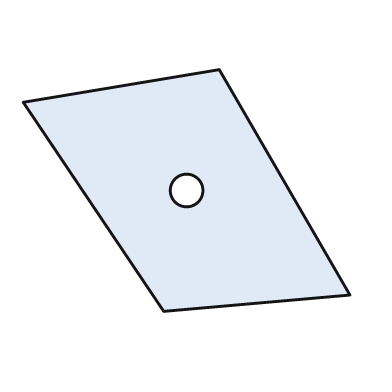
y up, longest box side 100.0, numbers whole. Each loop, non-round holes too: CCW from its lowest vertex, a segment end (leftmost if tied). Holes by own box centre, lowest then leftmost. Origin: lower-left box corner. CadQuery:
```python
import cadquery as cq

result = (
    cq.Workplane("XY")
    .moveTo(43.0, 0.0)
    .lineTo(100.0, 5.0)
    .lineTo(60.0, 74.0)
    .lineTo(0.0, 64.0)
    .close()
    .moveTo(50.0, 37.0)
    .circle(5.0)
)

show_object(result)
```